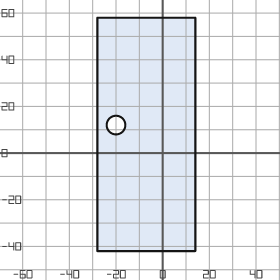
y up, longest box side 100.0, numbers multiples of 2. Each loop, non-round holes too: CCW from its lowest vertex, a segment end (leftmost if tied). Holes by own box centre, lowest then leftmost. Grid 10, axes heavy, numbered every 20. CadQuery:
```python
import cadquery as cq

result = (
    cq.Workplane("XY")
    .moveTo(-28.0, -42.0)
    .lineTo(14.0, -42.0)
    .lineTo(14.0, 58.0)
    .lineTo(-28.0, 58.0)
    .close()
    .moveTo(-20.0, 12.0)
    .circle(4.0)
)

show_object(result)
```